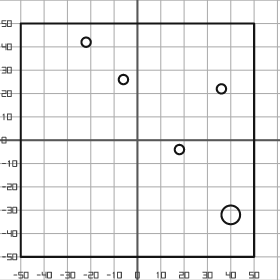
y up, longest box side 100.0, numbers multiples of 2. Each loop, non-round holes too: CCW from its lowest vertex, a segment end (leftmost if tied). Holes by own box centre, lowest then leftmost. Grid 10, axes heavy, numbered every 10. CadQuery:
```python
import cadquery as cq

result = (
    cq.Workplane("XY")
    .moveTo(-50.0, -50.0)
    .lineTo(50.0, -50.0)
    .lineTo(50.0, 50.0)
    .lineTo(-50.0, 50.0)
    .close()
    .moveTo(40.0, -32.0)
    .circle(4.0)
    .moveTo(18.0, -4.0)
    .circle(2.0)
    .moveTo(36.0, 22.0)
    .circle(2.0)
    .moveTo(-6.0, 26.0)
    .circle(2.0)
    .moveTo(-22.0, 42.0)
    .circle(2.0)
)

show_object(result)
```